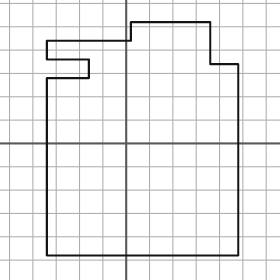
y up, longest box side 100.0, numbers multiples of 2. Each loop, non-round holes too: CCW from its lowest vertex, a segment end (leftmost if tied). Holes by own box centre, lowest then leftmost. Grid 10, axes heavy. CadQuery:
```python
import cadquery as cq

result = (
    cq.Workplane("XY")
    .moveTo(-34.0, -48.0)
    .lineTo(48.0, -48.0)
    .lineTo(48.0, 34.0)
    .lineTo(36.0, 34.0)
    .lineTo(36.0, 52.0)
    .lineTo(2.0, 52.0)
    .lineTo(2.0, 44.0)
    .lineTo(-34.0, 44.0)
    .lineTo(-34.0, 36.0)
    .lineTo(-16.0, 36.0)
    .lineTo(-16.0, 28.0)
    .lineTo(-34.0, 28.0)
    .close()
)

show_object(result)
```